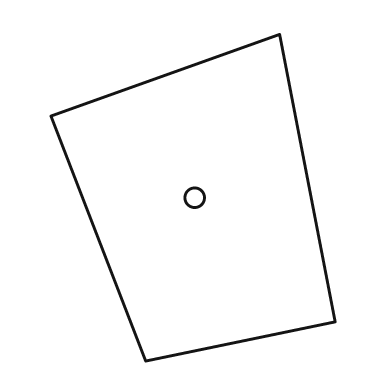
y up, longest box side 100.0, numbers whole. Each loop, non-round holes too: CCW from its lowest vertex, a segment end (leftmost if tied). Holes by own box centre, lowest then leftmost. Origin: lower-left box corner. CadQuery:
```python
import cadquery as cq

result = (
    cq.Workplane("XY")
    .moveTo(29.0, 0.0)
    .lineTo(87.0, 12.0)
    .lineTo(70.0, 100.0)
    .lineTo(0.0, 75.0)
    .close()
    .moveTo(44.0, 50.0)
    .circle(3.0)
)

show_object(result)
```